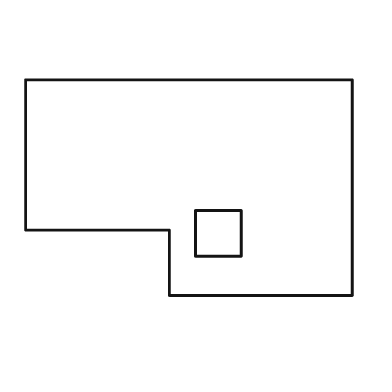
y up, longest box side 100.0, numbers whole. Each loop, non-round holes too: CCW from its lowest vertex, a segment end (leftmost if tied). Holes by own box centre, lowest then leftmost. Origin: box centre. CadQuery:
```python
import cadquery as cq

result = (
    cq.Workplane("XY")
    .moveTo(-6.0, -33.0)
    .lineTo(50.0, -33.0)
    .lineTo(50.0, 33.0)
    .lineTo(-50.0, 33.0)
    .lineTo(-50.0, -13.0)
    .lineTo(-6.0, -13.0)
    .close()
    .moveTo(2.0, -21.0)
    .lineTo(16.0, -21.0)
    .lineTo(16.0, -7.0)
    .lineTo(2.0, -7.0)
    .close()
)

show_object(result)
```